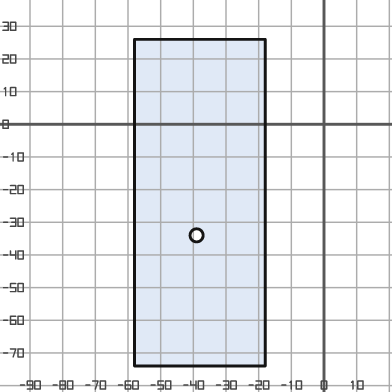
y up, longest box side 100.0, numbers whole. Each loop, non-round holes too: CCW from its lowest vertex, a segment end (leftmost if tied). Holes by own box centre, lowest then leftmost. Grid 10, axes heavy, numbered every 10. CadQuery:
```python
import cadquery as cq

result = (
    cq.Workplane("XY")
    .moveTo(-58.0, -74.0)
    .lineTo(-18.0, -74.0)
    .lineTo(-18.0, 26.0)
    .lineTo(-58.0, 26.0)
    .close()
    .moveTo(-39.0, -34.0)
    .circle(2.0)
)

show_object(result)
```